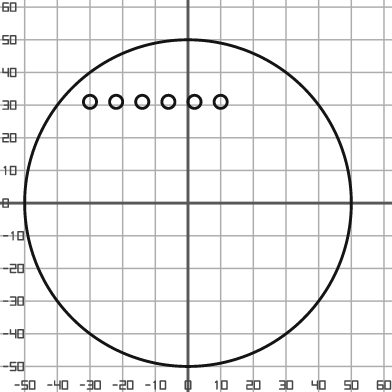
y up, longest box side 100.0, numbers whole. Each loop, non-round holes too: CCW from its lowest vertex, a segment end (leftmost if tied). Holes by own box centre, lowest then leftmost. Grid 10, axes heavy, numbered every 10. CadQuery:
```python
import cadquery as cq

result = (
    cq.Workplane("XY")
    .moveTo(0.0, 0.0)
    .circle(50.0)
    .moveTo(-30.0, 31.0)
    .circle(2.0)
    .moveTo(-22.0, 31.0)
    .circle(2.0)
    .moveTo(-14.0, 31.0)
    .circle(2.0)
    .moveTo(-6.0, 31.0)
    .circle(2.0)
    .moveTo(2.0, 31.0)
    .circle(2.0)
    .moveTo(10.0, 31.0)
    .circle(2.0)
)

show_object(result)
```